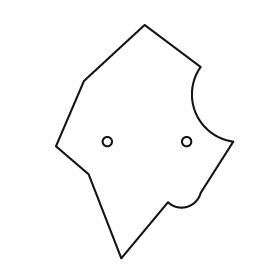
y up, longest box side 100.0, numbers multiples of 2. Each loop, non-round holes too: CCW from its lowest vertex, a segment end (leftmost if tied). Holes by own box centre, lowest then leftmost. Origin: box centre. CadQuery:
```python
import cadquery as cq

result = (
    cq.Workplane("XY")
    .moveTo(-10.0, -50.0)
    .lineTo(10.0, -26.0)
    .threePointArc((18.0, -28.0), (24.0, -22.0))
    .lineTo(38.0, 0.0)
    .threePointArc((22.0, 12.0), (24.0, 32.0))
    .lineTo(0.0, 50.0)
    .lineTo(-26.0, 26.0)
    .lineTo(-38.0, -2.0)
    .lineTo(-24.0, -14.0)
    .close()
    .moveTo(-16.0, 0.0)
    .circle(2.0)
    .moveTo(18.0, 0.0)
    .circle(2.0)
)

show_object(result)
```